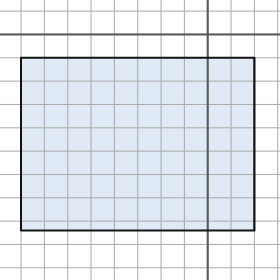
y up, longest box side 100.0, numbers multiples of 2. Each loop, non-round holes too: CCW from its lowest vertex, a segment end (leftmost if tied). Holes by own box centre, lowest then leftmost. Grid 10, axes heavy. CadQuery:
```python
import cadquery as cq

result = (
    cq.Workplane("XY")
    .moveTo(-80.0, -84.0)
    .lineTo(20.0, -84.0)
    .lineTo(20.0, -10.0)
    .lineTo(-80.0, -10.0)
    .close()
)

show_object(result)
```